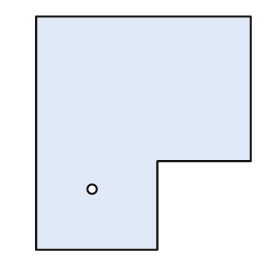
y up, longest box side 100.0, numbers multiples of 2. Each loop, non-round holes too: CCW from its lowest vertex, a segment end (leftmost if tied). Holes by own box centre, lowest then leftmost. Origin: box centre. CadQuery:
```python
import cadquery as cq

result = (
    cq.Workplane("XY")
    .moveTo(-46.0, -50.0)
    .lineTo(6.0, -50.0)
    .lineTo(6.0, -12.0)
    .lineTo(46.0, -12.0)
    .lineTo(46.0, 50.0)
    .lineTo(-46.0, 50.0)
    .close()
    .moveTo(-22.0, -24.0)
    .circle(2.0)
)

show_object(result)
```